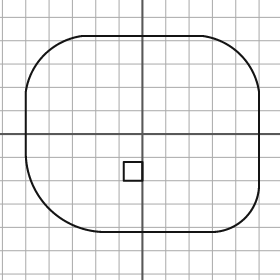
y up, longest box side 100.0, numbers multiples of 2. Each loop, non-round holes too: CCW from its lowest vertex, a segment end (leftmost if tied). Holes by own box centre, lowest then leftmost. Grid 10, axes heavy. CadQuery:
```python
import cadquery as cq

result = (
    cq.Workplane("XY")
    .moveTo(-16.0, -42.0)
    .lineTo(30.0, -42.0)
    .threePointArc((44.0, -36.0), (50.0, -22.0))
    .lineTo(50.0, 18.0)
    .threePointArc((42.0, 34.0), (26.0, 42.0))
    .lineTo(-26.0, 42.0)
    .threePointArc((-42.0, 34.0), (-50.0, 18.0))
    .lineTo(-50.0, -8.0)
    .threePointArc((-40.0, -32.0), (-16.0, -42.0))
    .close()
    .moveTo(-8.0, -20.0)
    .lineTo(0.0, -20.0)
    .lineTo(0.0, -12.0)
    .lineTo(-8.0, -12.0)
    .close()
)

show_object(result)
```